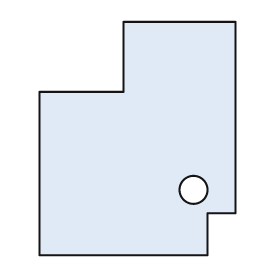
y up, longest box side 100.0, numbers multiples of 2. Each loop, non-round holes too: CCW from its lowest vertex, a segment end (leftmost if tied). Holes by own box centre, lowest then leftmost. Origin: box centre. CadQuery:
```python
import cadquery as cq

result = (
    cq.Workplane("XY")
    .moveTo(-42.0, -50.0)
    .lineTo(30.0, -50.0)
    .lineTo(30.0, -32.0)
    .lineTo(42.0, -32.0)
    .lineTo(42.0, 50.0)
    .lineTo(-6.0, 50.0)
    .lineTo(-6.0, 20.0)
    .lineTo(-42.0, 20.0)
    .close()
    .moveTo(24.0, -22.0)
    .circle(6.0)
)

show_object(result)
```